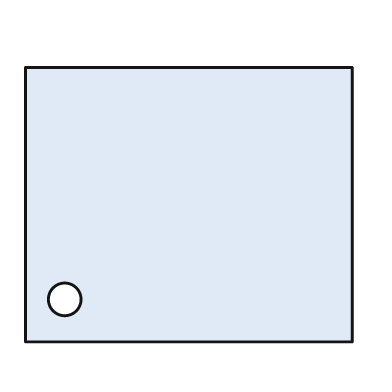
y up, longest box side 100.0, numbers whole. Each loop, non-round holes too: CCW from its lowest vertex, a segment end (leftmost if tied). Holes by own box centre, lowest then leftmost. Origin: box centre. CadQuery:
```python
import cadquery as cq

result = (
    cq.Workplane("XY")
    .moveTo(-50.0, -42.0)
    .lineTo(50.0, -42.0)
    .lineTo(50.0, 42.0)
    .lineTo(-50.0, 42.0)
    .close()
    .moveTo(-38.0, -29.0)
    .circle(5.0)
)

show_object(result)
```